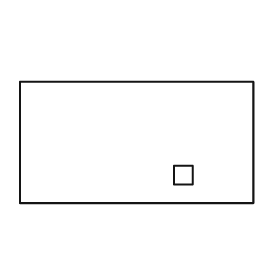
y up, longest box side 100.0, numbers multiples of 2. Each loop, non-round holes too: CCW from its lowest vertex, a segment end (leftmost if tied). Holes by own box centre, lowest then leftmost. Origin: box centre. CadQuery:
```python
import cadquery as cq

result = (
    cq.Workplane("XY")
    .moveTo(-50.0, -26.0)
    .lineTo(50.0, -26.0)
    .lineTo(50.0, 26.0)
    .lineTo(-50.0, 26.0)
    .close()
    .moveTo(16.0, -18.0)
    .lineTo(24.0, -18.0)
    .lineTo(24.0, -10.0)
    .lineTo(16.0, -10.0)
    .close()
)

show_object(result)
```